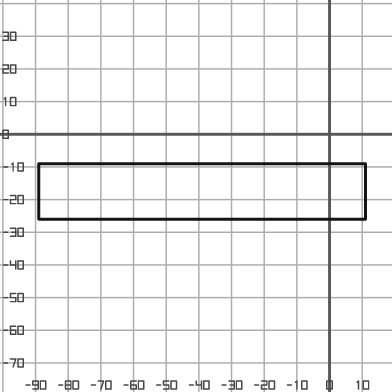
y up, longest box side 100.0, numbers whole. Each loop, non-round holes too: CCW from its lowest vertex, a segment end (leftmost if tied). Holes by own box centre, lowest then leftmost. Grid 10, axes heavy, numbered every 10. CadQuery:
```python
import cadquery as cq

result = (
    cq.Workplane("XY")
    .moveTo(-89.0, -26.0)
    .lineTo(11.0, -26.0)
    .lineTo(11.0, -9.0)
    .lineTo(-89.0, -9.0)
    .close()
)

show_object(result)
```